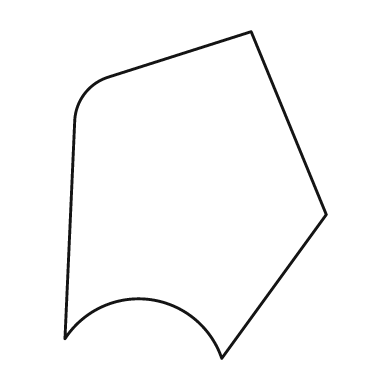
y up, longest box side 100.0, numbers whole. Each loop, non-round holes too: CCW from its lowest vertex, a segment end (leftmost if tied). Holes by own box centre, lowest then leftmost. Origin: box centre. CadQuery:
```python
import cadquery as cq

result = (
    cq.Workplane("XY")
    .moveTo(8.0, -50.0)
    .lineTo(40.0, -6.0)
    .lineTo(17.0, 50.0)
    .lineTo(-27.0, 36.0)
    .threePointArc((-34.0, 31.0), (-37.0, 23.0))
    .lineTo(-40.0, -44.0)
    .threePointArc((-14.0, -32.0), (8.0, -50.0))
    .close()
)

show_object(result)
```